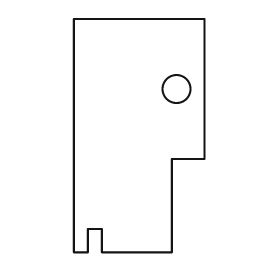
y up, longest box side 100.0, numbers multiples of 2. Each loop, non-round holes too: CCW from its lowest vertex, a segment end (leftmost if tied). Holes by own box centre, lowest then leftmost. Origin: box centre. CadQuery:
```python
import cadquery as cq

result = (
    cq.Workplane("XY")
    .moveTo(-28.0, -50.0)
    .lineTo(-22.0, -50.0)
    .lineTo(-22.0, -40.0)
    .lineTo(-16.0, -40.0)
    .lineTo(-16.0, -50.0)
    .lineTo(14.0, -50.0)
    .lineTo(14.0, -10.0)
    .lineTo(28.0, -10.0)
    .lineTo(28.0, 50.0)
    .lineTo(-28.0, 50.0)
    .close()
    .moveTo(16.0, 20.0)
    .circle(6.0)
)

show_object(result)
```